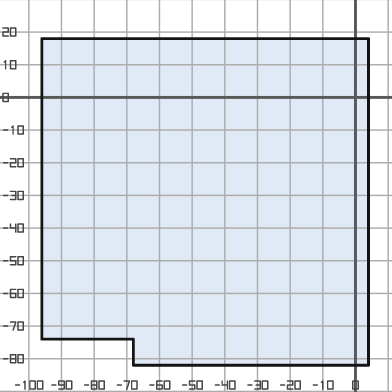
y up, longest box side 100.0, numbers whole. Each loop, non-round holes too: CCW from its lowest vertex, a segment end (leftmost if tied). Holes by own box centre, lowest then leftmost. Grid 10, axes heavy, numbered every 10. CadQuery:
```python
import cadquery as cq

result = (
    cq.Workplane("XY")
    .moveTo(-68.0, -82.0)
    .lineTo(4.0, -82.0)
    .lineTo(4.0, 18.0)
    .lineTo(-96.0, 18.0)
    .lineTo(-96.0, -74.0)
    .lineTo(-68.0, -74.0)
    .close()
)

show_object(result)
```